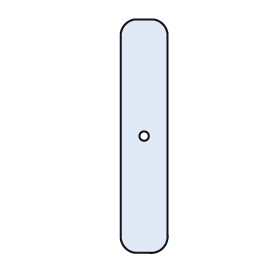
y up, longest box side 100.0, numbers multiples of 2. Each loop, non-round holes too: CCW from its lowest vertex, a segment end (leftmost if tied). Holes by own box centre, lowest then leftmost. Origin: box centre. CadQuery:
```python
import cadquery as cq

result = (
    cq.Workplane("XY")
    .moveTo(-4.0, -50.0)
    .lineTo(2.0, -50.0)
    .threePointArc((8.0, -48.0), (10.0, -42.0))
    .lineTo(10.0, 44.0)
    .threePointArc((8.0, 48.0), (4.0, 50.0))
    .lineTo(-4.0, 50.0)
    .threePointArc((-8.0, 48.0), (-10.0, 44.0))
    .lineTo(-10.0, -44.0)
    .threePointArc((-8.0, -48.0), (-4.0, -50.0))
    .close()
    .moveTo(0.0, 0.0)
    .circle(2.0)
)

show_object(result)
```